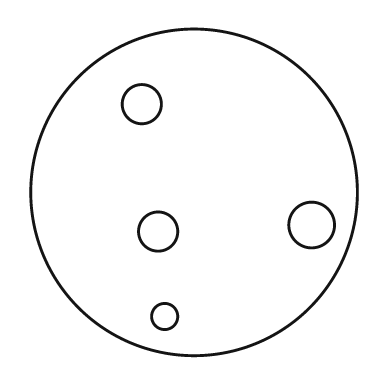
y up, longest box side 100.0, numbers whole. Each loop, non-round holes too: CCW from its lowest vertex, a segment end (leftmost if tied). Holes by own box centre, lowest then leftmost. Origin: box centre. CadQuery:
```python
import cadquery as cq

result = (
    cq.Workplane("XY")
    .moveTo(0.0, 0.0)
    .circle(50.0)
    .moveTo(-9.0, -38.0)
    .circle(4.0)
    .moveTo(-11.0, -12.0)
    .circle(6.0)
    .moveTo(36.0, -10.0)
    .circle(7.0)
    .moveTo(-16.0, 27.0)
    .circle(6.0)
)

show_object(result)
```